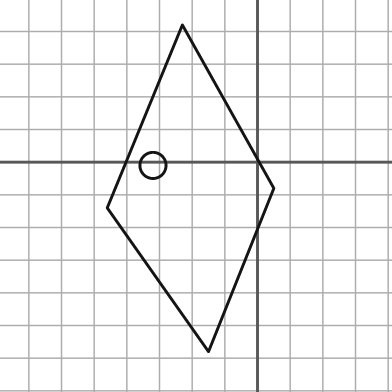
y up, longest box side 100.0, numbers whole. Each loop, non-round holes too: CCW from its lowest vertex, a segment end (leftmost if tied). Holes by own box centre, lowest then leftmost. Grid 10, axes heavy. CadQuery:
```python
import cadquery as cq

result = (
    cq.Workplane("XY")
    .moveTo(-15.0, -58.0)
    .lineTo(5.0, -8.0)
    .lineTo(-23.0, 42.0)
    .lineTo(-46.0, -14.0)
    .close()
    .moveTo(-32.0, -1.0)
    .circle(4.0)
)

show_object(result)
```